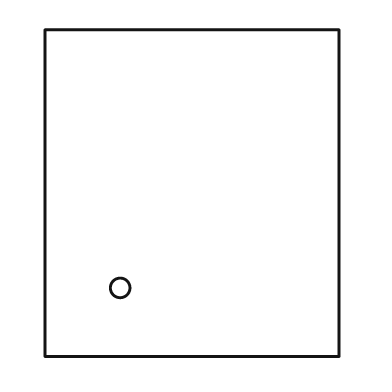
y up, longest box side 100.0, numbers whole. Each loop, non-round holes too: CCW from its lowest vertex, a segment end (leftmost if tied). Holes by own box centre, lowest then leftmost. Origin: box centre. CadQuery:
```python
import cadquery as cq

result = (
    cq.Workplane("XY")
    .moveTo(-45.0, -50.0)
    .lineTo(45.0, -50.0)
    .lineTo(45.0, 50.0)
    .lineTo(-45.0, 50.0)
    .close()
    .moveTo(-22.0, -29.0)
    .circle(3.0)
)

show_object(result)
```